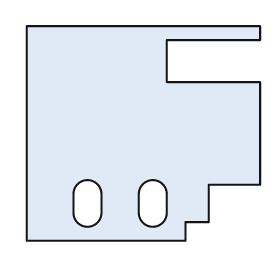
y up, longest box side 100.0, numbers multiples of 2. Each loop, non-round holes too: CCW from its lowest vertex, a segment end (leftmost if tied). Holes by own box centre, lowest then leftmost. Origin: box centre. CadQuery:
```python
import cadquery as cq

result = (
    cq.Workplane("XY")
    .moveTo(-50.0, -46.0)
    .lineTo(18.0, -46.0)
    .lineTo(18.0, -38.0)
    .lineTo(28.0, -38.0)
    .lineTo(28.0, -22.0)
    .lineTo(50.0, -22.0)
    .lineTo(50.0, 22.0)
    .lineTo(10.0, 22.0)
    .lineTo(10.0, 40.0)
    .lineTo(50.0, 40.0)
    .lineTo(50.0, 46.0)
    .lineTo(-50.0, 46.0)
    .close()
    .moveTo(-30.0, -34.0)
    .threePointArc((-24.0, -40.0), (-18.0, -34.0))
    .lineTo(-18.0, -26.0)
    .threePointArc((-24.0, -20.0), (-30.0, -26.0))
    .close()
    .moveTo(-2.0, -34.0)
    .threePointArc((4.0, -40.0), (10.0, -34.0))
    .lineTo(10.0, -26.0)
    .threePointArc((4.0, -20.0), (-2.0, -26.0))
    .close()
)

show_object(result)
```